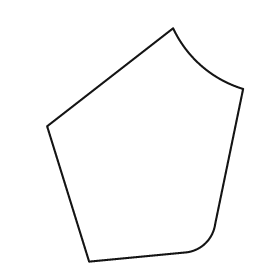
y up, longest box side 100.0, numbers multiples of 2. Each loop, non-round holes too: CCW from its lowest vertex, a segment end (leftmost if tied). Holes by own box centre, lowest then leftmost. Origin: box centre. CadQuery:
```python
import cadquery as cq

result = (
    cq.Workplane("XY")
    .moveTo(-24.0, -50.0)
    .lineTo(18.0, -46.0)
    .threePointArc((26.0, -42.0), (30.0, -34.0))
    .lineTo(42.0, 24.0)
    .threePointArc((24.0, 34.0), (12.0, 50.0))
    .lineTo(-42.0, 8.0)
    .close()
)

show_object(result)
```